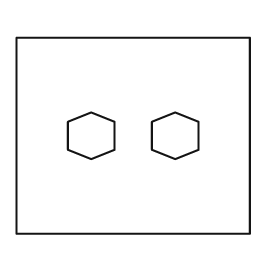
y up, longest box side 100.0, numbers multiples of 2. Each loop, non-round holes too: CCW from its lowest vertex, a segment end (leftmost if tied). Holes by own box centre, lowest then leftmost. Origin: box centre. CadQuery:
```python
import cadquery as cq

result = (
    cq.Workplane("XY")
    .moveTo(-50.0, -42.0)
    .lineTo(50.0, -42.0)
    .lineTo(50.0, 42.0)
    .lineTo(-50.0, 42.0)
    .close()
    .moveTo(-18.0, -10.0)
    .lineTo(-8.0, -6.0)
    .lineTo(-8.0, 6.0)
    .lineTo(-18.0, 10.0)
    .lineTo(-28.0, 6.0)
    .lineTo(-28.0, -6.0)
    .close()
    .moveTo(18.0, -10.0)
    .lineTo(28.0, -6.0)
    .lineTo(28.0, 6.0)
    .lineTo(18.0, 10.0)
    .lineTo(8.0, 6.0)
    .lineTo(8.0, -6.0)
    .close()
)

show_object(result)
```